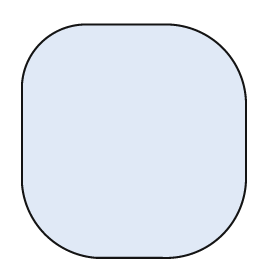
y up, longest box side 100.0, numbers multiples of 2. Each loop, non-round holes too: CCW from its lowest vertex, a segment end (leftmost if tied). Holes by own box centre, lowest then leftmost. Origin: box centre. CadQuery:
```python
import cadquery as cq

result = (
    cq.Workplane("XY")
    .moveTo(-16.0, -50.0)
    .lineTo(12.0, -50.0)
    .threePointArc((38.0, -40.0), (48.0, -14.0))
    .lineTo(48.0, 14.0)
    .threePointArc((38.0, 40.0), (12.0, 50.0))
    .lineTo(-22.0, 50.0)
    .threePointArc((-40.0, 42.0), (-48.0, 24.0))
    .lineTo(-48.0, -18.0)
    .threePointArc((-38.0, -40.0), (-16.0, -50.0))
    .close()
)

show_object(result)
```